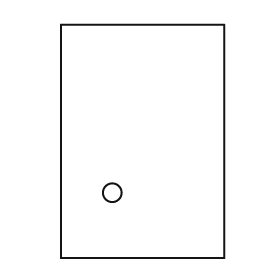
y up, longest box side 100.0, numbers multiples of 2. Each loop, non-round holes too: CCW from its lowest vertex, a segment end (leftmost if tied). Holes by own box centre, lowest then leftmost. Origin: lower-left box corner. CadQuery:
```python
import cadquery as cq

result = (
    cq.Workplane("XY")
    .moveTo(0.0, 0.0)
    .lineTo(70.0, 0.0)
    .lineTo(70.0, 100.0)
    .lineTo(0.0, 100.0)
    .close()
    .moveTo(22.0, 28.0)
    .circle(4.0)
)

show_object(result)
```